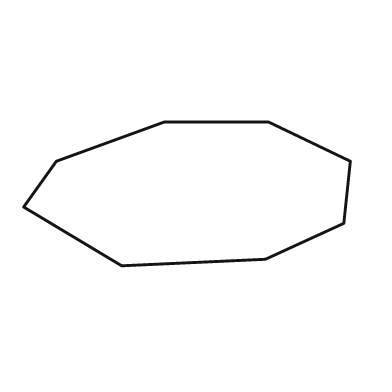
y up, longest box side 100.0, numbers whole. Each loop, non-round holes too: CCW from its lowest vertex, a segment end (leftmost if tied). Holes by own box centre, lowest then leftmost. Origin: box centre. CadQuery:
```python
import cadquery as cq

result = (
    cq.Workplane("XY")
    .moveTo(-20.0, -22.0)
    .lineTo(24.0, -20.0)
    .lineTo(48.0, -9.0)
    .lineTo(50.0, 10.0)
    .lineTo(25.0, 22.0)
    .lineTo(-7.0, 22.0)
    .lineTo(-40.0, 10.0)
    .lineTo(-50.0, -4.0)
    .close()
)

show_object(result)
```